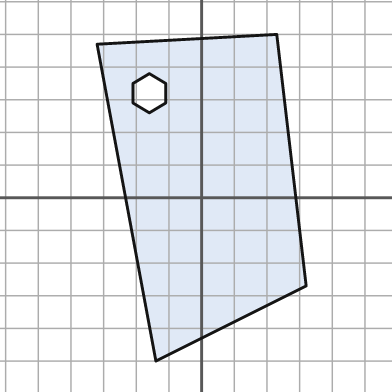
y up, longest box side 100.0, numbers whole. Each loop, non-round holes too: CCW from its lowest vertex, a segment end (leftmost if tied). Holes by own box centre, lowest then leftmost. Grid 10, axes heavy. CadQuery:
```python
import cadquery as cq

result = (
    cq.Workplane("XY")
    .moveTo(-14.0, -50.0)
    .lineTo(32.0, -27.0)
    .lineTo(23.0, 50.0)
    .lineTo(-32.0, 47.0)
    .close()
    .moveTo(-16.0, 26.0)
    .lineTo(-11.0, 29.0)
    .lineTo(-11.0, 35.0)
    .lineTo(-16.0, 38.0)
    .lineTo(-21.0, 35.0)
    .lineTo(-21.0, 29.0)
    .close()
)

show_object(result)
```